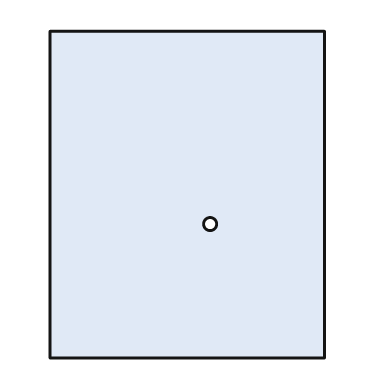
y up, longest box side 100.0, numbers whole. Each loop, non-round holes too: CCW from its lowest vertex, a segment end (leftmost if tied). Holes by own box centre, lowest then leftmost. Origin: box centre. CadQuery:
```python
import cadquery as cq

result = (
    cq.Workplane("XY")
    .moveTo(-42.0, -50.0)
    .lineTo(42.0, -50.0)
    .lineTo(42.0, 50.0)
    .lineTo(-42.0, 50.0)
    .close()
    .moveTo(7.0, -9.0)
    .circle(2.0)
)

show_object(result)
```